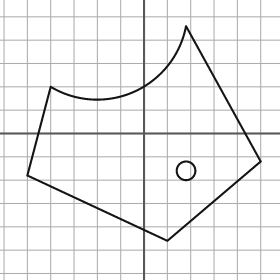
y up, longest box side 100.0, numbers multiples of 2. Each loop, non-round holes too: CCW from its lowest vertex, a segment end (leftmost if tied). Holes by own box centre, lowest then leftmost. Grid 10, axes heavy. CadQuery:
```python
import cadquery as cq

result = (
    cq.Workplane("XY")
    .moveTo(10.0, -46.0)
    .lineTo(50.0, -12.0)
    .lineTo(18.0, 46.0)
    .threePointArc((-4.0, 18.0), (-40.0, 20.0))
    .lineTo(-50.0, -18.0)
    .close()
    .moveTo(18.0, -16.0)
    .circle(4.0)
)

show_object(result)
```